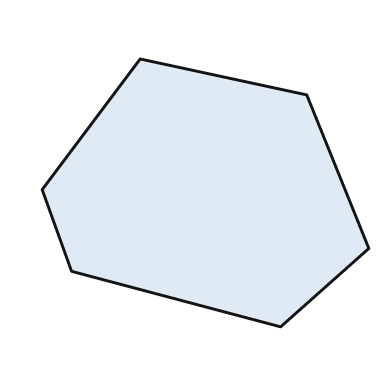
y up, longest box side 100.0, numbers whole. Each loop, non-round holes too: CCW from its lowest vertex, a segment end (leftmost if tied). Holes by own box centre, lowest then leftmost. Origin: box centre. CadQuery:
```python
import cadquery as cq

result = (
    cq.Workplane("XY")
    .moveTo(23.0, -41.0)
    .lineTo(50.0, -17.0)
    .lineTo(31.0, 30.0)
    .lineTo(-20.0, 41.0)
    .lineTo(-50.0, 1.0)
    .lineTo(-41.0, -24.0)
    .close()
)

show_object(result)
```